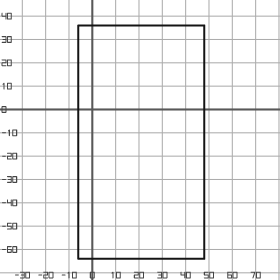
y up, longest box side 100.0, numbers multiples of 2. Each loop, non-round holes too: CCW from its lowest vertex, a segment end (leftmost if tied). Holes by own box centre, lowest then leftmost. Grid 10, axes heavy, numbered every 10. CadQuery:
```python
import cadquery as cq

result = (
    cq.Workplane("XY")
    .moveTo(-6.0, -64.0)
    .lineTo(48.0, -64.0)
    .lineTo(48.0, 36.0)
    .lineTo(-6.0, 36.0)
    .close()
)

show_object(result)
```